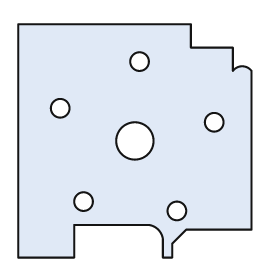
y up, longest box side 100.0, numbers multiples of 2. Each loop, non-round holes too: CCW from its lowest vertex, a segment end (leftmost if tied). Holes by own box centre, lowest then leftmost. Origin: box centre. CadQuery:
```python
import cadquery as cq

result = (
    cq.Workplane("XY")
    .moveTo(-50.0, -50.0)
    .lineTo(-26.0, -50.0)
    .lineTo(-26.0, -36.0)
    .lineTo(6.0, -36.0)
    .threePointArc((10.0, -38.0), (12.0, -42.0))
    .lineTo(12.0, -50.0)
    .lineTo(16.0, -50.0)
    .lineTo(16.0, -44.0)
    .lineTo(22.0, -38.0)
    .lineTo(50.0, -38.0)
    .lineTo(50.0, 30.0)
    .threePointArc((46.0, 32.0), (42.0, 30.0))
    .lineTo(42.0, 40.0)
    .lineTo(24.0, 40.0)
    .lineTo(24.0, 50.0)
    .lineTo(-50.0, 50.0)
    .close()
    .moveTo(18.0, -30.0)
    .circle(4.0)
    .moveTo(-22.0, -26.0)
    .circle(4.0)
    .moveTo(0.0, 0.0)
    .circle(8.0)
    .moveTo(34.0, 8.0)
    .circle(4.0)
    .moveTo(-32.0, 14.0)
    .circle(4.0)
    .moveTo(2.0, 34.0)
    .circle(4.0)
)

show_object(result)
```